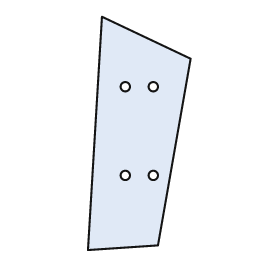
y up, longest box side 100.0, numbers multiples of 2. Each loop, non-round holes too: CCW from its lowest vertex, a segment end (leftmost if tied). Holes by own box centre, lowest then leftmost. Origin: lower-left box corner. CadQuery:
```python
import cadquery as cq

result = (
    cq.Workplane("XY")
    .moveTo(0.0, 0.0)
    .lineTo(30.0, 2.0)
    .lineTo(44.0, 82.0)
    .lineTo(6.0, 100.0)
    .close()
    .moveTo(16.0, 32.0)
    .circle(2.0)
    .moveTo(28.0, 32.0)
    .circle(2.0)
    .moveTo(16.0, 70.0)
    .circle(2.0)
    .moveTo(28.0, 70.0)
    .circle(2.0)
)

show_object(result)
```